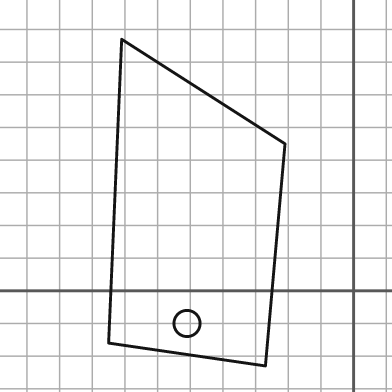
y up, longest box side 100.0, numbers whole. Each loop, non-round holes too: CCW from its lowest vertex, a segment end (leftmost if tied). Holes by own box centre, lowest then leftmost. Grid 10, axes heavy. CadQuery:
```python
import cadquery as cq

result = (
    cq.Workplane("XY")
    .moveTo(-27.0, -23.0)
    .lineTo(-21.0, 45.0)
    .lineTo(-71.0, 77.0)
    .lineTo(-75.0, -16.0)
    .close()
    .moveTo(-51.0, -10.0)
    .circle(4.0)
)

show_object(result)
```